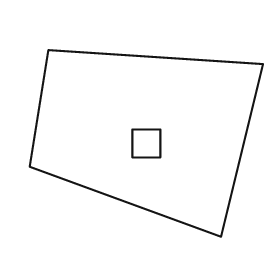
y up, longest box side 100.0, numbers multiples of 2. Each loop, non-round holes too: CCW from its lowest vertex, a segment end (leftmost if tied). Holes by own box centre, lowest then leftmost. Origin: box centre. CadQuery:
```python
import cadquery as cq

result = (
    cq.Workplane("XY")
    .moveTo(32.0, -40.0)
    .lineTo(50.0, 34.0)
    .lineTo(-42.0, 40.0)
    .lineTo(-50.0, -10.0)
    .close()
    .moveTo(-6.0, -6.0)
    .lineTo(6.0, -6.0)
    .lineTo(6.0, 6.0)
    .lineTo(-6.0, 6.0)
    .close()
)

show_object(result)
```